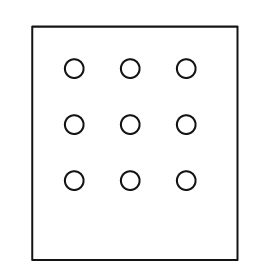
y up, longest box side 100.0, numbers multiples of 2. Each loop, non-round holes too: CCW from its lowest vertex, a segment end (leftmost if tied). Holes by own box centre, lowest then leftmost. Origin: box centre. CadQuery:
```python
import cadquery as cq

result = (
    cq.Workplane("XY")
    .moveTo(-44.0, -50.0)
    .lineTo(44.0, -50.0)
    .lineTo(44.0, 50.0)
    .lineTo(-44.0, 50.0)
    .close()
    .moveTo(-26.0, -16.0)
    .circle(4.0)
    .moveTo(-2.0, -16.0)
    .circle(4.0)
    .moveTo(22.0, -16.0)
    .circle(4.0)
    .moveTo(-26.0, 8.0)
    .circle(4.0)
    .moveTo(-2.0, 8.0)
    .circle(4.0)
    .moveTo(22.0, 8.0)
    .circle(4.0)
    .moveTo(-26.0, 32.0)
    .circle(4.0)
    .moveTo(-2.0, 32.0)
    .circle(4.0)
    .moveTo(22.0, 32.0)
    .circle(4.0)
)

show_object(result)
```